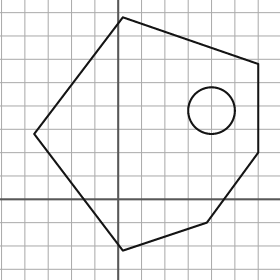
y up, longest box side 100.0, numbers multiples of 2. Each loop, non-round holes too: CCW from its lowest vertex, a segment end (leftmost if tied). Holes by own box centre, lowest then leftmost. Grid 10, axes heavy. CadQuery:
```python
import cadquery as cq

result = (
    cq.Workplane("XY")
    .moveTo(2.0, -22.0)
    .lineTo(38.0, -10.0)
    .lineTo(60.0, 20.0)
    .lineTo(60.0, 58.0)
    .lineTo(2.0, 78.0)
    .lineTo(-36.0, 28.0)
    .close()
    .moveTo(40.0, 38.0)
    .circle(10.0)
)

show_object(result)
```